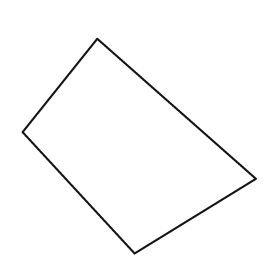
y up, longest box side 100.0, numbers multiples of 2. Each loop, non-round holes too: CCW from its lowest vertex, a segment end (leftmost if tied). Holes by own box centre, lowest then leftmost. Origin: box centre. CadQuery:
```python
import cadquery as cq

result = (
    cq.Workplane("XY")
    .moveTo(-2.0, -46.0)
    .lineTo(50.0, -14.0)
    .lineTo(-18.0, 46.0)
    .lineTo(-50.0, 6.0)
    .close()
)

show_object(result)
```